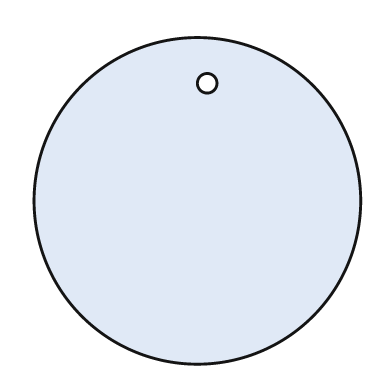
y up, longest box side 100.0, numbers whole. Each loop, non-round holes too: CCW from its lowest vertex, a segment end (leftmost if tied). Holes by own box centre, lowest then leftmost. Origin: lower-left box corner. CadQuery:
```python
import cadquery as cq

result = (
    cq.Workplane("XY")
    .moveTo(50.0, 50.0)
    .circle(50.0)
    .moveTo(53.0, 86.0)
    .circle(3.0)
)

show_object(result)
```